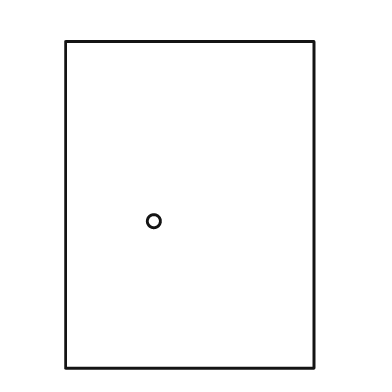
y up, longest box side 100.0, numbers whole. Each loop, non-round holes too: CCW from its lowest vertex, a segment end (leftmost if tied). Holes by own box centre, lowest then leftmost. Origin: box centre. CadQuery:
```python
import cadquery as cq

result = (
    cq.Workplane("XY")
    .moveTo(-38.0, -50.0)
    .lineTo(38.0, -50.0)
    .lineTo(38.0, 50.0)
    .lineTo(-38.0, 50.0)
    .close()
    .moveTo(-11.0, -5.0)
    .circle(2.0)
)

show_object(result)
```